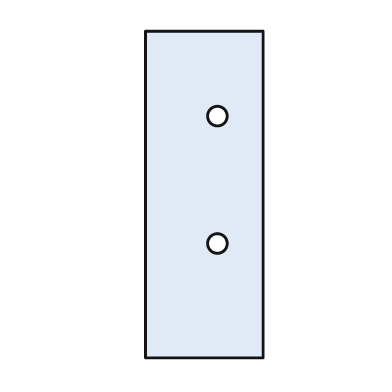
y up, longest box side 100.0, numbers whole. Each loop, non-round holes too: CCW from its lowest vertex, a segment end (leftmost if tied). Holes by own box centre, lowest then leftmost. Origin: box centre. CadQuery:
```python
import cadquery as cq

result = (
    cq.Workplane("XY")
    .moveTo(-18.0, -50.0)
    .lineTo(18.0, -50.0)
    .lineTo(18.0, 50.0)
    .lineTo(-18.0, 50.0)
    .close()
    .moveTo(4.0, -15.0)
    .circle(3.0)
    .moveTo(4.0, 24.0)
    .circle(3.0)
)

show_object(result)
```